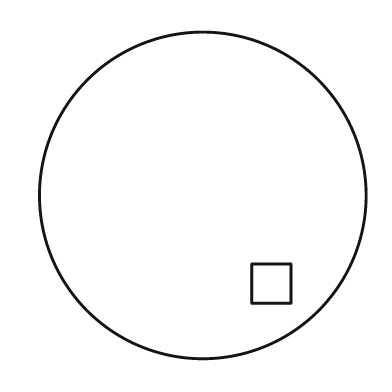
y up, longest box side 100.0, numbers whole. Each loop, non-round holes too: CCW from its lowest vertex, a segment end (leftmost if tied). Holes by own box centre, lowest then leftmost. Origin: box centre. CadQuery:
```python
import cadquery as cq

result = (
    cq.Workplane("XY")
    .moveTo(0.0, 0.0)
    .circle(50.0)
    .moveTo(15.0, -33.0)
    .lineTo(27.0, -33.0)
    .lineTo(27.0, -21.0)
    .lineTo(15.0, -21.0)
    .close()
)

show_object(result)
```